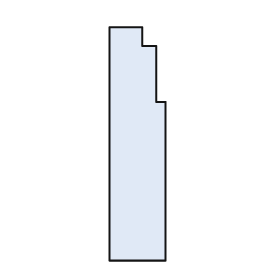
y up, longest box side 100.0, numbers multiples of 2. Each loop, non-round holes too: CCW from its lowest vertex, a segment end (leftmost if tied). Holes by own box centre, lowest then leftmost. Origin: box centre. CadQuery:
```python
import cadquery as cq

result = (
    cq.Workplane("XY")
    .moveTo(-12.0, -50.0)
    .lineTo(12.0, -50.0)
    .lineTo(12.0, 18.0)
    .lineTo(8.0, 18.0)
    .lineTo(8.0, 42.0)
    .lineTo(2.0, 42.0)
    .lineTo(2.0, 50.0)
    .lineTo(-12.0, 50.0)
    .close()
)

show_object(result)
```